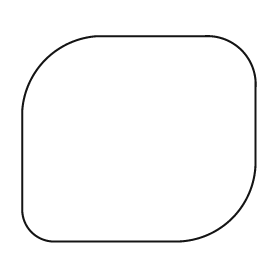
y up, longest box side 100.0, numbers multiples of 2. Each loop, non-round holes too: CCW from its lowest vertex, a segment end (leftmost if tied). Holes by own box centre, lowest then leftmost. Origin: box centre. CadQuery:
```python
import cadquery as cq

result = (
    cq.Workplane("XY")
    .moveTo(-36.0, -44.0)
    .lineTo(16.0, -44.0)
    .threePointArc((40.0, -34.0), (50.0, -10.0))
    .lineTo(50.0, 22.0)
    .threePointArc((44.0, 38.0), (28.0, 44.0))
    .lineTo(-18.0, 44.0)
    .threePointArc((-40.0, 34.0), (-50.0, 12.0))
    .lineTo(-50.0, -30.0)
    .threePointArc((-46.0, -40.0), (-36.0, -44.0))
    .close()
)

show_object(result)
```